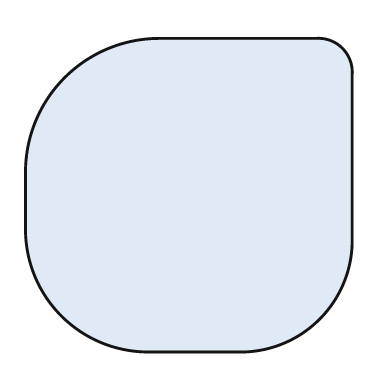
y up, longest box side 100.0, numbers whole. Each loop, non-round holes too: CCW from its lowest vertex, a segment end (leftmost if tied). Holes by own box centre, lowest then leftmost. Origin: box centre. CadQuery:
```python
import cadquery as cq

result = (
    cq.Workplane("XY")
    .moveTo(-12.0, -48.0)
    .lineTo(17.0, -48.0)
    .threePointArc((40.0, -38.0), (50.0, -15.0))
    .lineTo(50.0, 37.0)
    .threePointArc((47.0, 45.0), (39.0, 48.0))
    .lineTo(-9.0, 48.0)
    .threePointArc((-38.0, 36.0), (-50.0, 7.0))
    .lineTo(-50.0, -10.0)
    .threePointArc((-39.0, -37.0), (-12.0, -48.0))
    .close()
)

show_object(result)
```